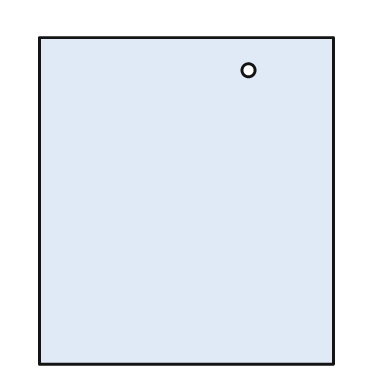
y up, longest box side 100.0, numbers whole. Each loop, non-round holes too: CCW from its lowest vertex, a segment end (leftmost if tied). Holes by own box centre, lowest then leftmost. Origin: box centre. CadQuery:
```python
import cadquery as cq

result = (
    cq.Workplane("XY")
    .moveTo(-45.0, -50.0)
    .lineTo(45.0, -50.0)
    .lineTo(45.0, 50.0)
    .lineTo(-45.0, 50.0)
    .close()
    .moveTo(19.0, 40.0)
    .circle(2.0)
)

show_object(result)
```